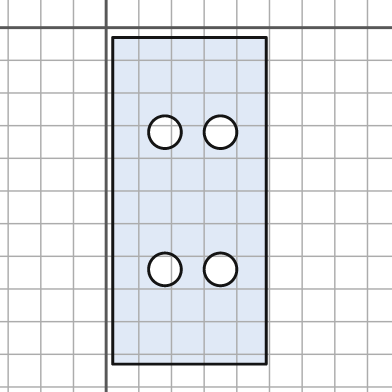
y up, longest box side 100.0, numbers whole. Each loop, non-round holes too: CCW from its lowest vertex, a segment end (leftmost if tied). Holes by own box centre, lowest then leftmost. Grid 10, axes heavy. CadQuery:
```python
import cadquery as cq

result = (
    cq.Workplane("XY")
    .moveTo(2.0, -103.0)
    .lineTo(49.0, -103.0)
    .lineTo(49.0, -3.0)
    .lineTo(2.0, -3.0)
    .close()
    .moveTo(18.0, -74.0)
    .circle(5.0)
    .moveTo(35.0, -74.0)
    .circle(5.0)
    .moveTo(18.0, -32.0)
    .circle(5.0)
    .moveTo(35.0, -32.0)
    .circle(5.0)
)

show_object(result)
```